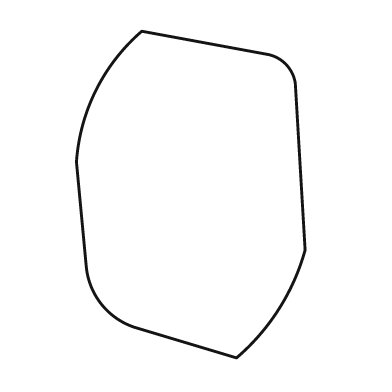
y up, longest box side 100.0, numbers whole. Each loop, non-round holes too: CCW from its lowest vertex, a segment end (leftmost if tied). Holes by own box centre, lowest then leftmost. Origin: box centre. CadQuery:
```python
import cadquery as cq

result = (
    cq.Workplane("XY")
    .moveTo(14.0, -50.0)
    .threePointArc((27.0, -35.0), (35.0, -17.0))
    .lineTo(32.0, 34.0)
    .threePointArc((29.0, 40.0), (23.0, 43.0))
    .lineTo(-15.0, 50.0)
    .threePointArc((-29.0, 32.0), (-35.0, 10.0))
    .lineTo(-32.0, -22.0)
    .threePointArc((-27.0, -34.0), (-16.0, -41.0))
    .close()
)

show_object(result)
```